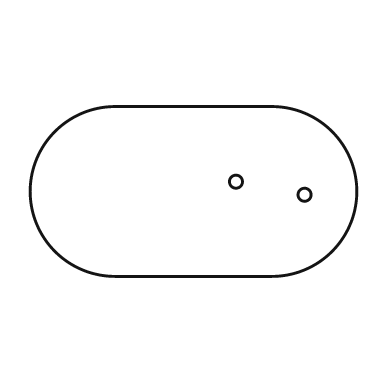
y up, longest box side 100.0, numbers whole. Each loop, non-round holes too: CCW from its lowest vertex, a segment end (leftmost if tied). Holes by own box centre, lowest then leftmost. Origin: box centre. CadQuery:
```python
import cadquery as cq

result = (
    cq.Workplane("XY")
    .moveTo(-24.0, -26.0)
    .lineTo(24.0, -26.0)
    .threePointArc((50.0, 0.0), (24.0, 26.0))
    .lineTo(-24.0, 26.0)
    .threePointArc((-50.0, 0.0), (-24.0, -26.0))
    .close()
    .moveTo(34.0, -1.0)
    .circle(2.0)
    .moveTo(13.0, 3.0)
    .circle(2.0)
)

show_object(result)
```